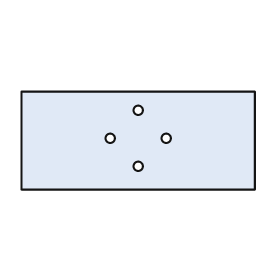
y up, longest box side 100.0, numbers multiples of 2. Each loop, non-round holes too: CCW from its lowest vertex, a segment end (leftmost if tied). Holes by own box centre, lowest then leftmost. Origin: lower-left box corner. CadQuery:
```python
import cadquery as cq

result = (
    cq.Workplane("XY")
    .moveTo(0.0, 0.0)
    .lineTo(100.0, 0.0)
    .lineTo(100.0, 42.0)
    .lineTo(0.0, 42.0)
    .close()
    .moveTo(50.0, 10.0)
    .circle(2.0)
    .moveTo(38.0, 22.0)
    .circle(2.0)
    .moveTo(62.0, 22.0)
    .circle(2.0)
    .moveTo(50.0, 34.0)
    .circle(2.0)
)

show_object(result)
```